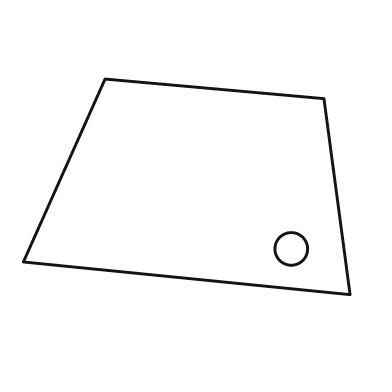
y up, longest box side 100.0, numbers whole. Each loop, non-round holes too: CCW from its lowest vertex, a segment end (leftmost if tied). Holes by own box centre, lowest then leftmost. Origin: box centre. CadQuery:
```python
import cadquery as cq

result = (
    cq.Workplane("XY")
    .moveTo(50.0, -33.0)
    .lineTo(42.0, 27.0)
    .lineTo(-25.0, 33.0)
    .lineTo(-50.0, -23.0)
    .close()
    .moveTo(32.0, -19.0)
    .circle(5.0)
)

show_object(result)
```